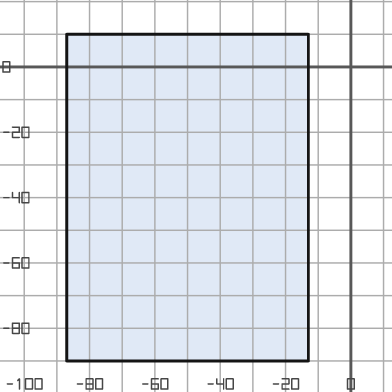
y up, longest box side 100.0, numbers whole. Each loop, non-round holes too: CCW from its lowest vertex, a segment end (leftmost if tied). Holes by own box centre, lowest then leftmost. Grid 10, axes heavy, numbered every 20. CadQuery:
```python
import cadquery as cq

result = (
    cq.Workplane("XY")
    .moveTo(-87.0, -90.0)
    .lineTo(-13.0, -90.0)
    .lineTo(-13.0, 10.0)
    .lineTo(-87.0, 10.0)
    .close()
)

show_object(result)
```